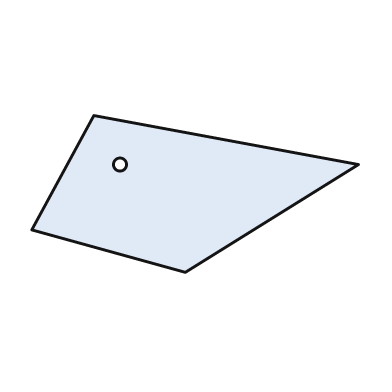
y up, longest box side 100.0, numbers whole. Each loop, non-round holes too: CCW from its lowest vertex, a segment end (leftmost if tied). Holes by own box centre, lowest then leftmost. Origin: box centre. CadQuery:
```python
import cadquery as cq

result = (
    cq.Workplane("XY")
    .moveTo(-3.0, -24.0)
    .lineTo(50.0, 9.0)
    .lineTo(-31.0, 24.0)
    .lineTo(-50.0, -11.0)
    .close()
    .moveTo(-23.0, 9.0)
    .circle(2.0)
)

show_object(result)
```